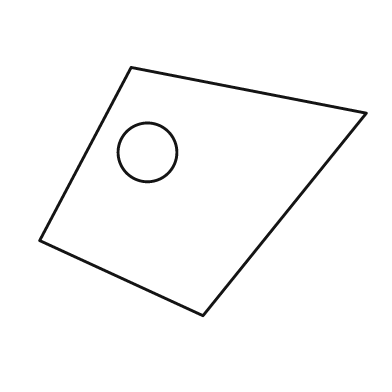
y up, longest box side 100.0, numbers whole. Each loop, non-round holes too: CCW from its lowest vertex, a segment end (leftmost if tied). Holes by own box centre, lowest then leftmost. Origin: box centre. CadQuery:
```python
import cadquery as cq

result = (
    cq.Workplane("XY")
    .moveTo(0.0, -38.0)
    .lineTo(50.0, 24.0)
    .lineTo(-22.0, 38.0)
    .lineTo(-50.0, -15.0)
    .close()
    .moveTo(-17.0, 12.0)
    .circle(9.0)
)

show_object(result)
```